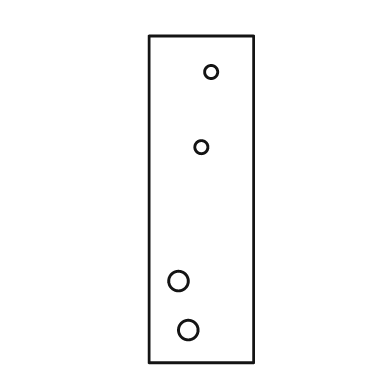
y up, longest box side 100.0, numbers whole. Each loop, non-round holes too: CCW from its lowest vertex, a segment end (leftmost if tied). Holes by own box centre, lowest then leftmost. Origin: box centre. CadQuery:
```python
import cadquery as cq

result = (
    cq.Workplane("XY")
    .moveTo(-16.0, -50.0)
    .lineTo(16.0, -50.0)
    .lineTo(16.0, 50.0)
    .lineTo(-16.0, 50.0)
    .close()
    .moveTo(-4.0, -40.0)
    .circle(3.0)
    .moveTo(-7.0, -25.0)
    .circle(3.0)
    .moveTo(0.0, 16.0)
    .circle(2.0)
    .moveTo(3.0, 39.0)
    .circle(2.0)
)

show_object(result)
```